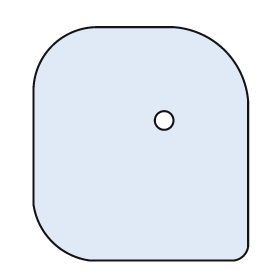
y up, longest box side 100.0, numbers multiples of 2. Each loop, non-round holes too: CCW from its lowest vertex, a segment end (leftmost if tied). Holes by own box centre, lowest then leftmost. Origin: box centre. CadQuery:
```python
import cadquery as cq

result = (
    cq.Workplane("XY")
    .moveTo(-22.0, -50.0)
    .lineTo(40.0, -50.0)
    .threePointArc((44.0, -48.0), (46.0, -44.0))
    .lineTo(46.0, 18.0)
    .threePointArc((36.0, 40.0), (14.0, 50.0))
    .lineTo(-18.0, 50.0)
    .threePointArc((-38.0, 42.0), (-46.0, 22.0))
    .lineTo(-46.0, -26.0)
    .threePointArc((-38.0, -42.0), (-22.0, -50.0))
    .close()
    .moveTo(10.0, 10.0)
    .circle(4.0)
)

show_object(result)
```